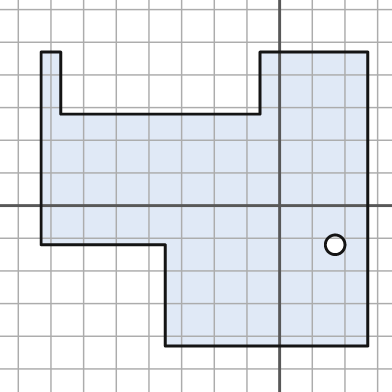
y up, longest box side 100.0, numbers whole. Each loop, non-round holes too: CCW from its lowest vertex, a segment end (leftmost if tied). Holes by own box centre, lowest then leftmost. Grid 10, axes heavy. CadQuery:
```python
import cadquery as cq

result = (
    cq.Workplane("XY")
    .moveTo(-35.0, -43.0)
    .lineTo(27.0, -43.0)
    .lineTo(27.0, 47.0)
    .lineTo(-6.0, 47.0)
    .lineTo(-6.0, 28.0)
    .lineTo(-67.0, 28.0)
    .lineTo(-67.0, 47.0)
    .lineTo(-73.0, 47.0)
    .lineTo(-73.0, -12.0)
    .lineTo(-35.0, -12.0)
    .close()
    .moveTo(17.0, -12.0)
    .circle(3.0)
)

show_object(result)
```